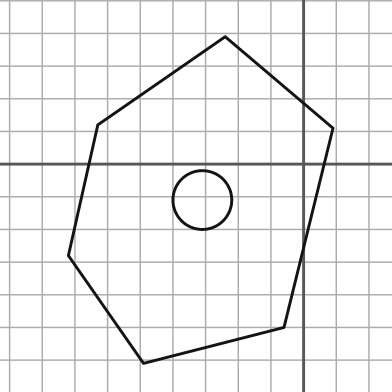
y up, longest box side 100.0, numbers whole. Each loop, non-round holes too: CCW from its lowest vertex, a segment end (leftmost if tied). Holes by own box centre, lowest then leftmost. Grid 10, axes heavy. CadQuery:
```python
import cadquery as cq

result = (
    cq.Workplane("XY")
    .moveTo(-49.0, -61.0)
    .lineTo(-6.0, -50.0)
    .lineTo(9.0, 11.0)
    .lineTo(-24.0, 39.0)
    .lineTo(-63.0, 12.0)
    .lineTo(-72.0, -28.0)
    .close()
    .moveTo(-31.0, -11.0)
    .circle(9.0)
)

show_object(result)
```